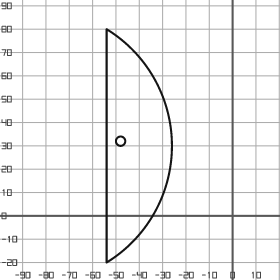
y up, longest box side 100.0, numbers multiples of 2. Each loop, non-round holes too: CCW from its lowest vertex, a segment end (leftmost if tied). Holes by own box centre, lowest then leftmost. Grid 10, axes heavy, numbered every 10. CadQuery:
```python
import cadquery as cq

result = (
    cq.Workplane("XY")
    .moveTo(-54.0, -20.0)
    .threePointArc((-26.0, 30.0), (-54.0, 80.0))
    .close()
    .moveTo(-48.0, 32.0)
    .circle(2.0)
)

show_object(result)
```